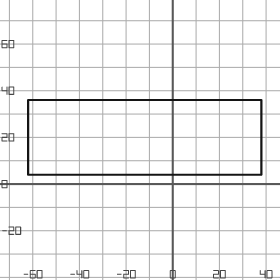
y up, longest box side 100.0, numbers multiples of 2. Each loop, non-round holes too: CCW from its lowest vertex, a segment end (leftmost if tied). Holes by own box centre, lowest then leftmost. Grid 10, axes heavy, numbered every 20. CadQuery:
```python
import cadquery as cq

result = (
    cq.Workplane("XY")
    .moveTo(-62.0, 4.0)
    .lineTo(38.0, 4.0)
    .lineTo(38.0, 36.0)
    .lineTo(-62.0, 36.0)
    .close()
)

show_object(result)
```